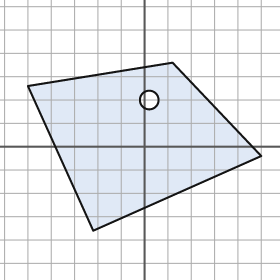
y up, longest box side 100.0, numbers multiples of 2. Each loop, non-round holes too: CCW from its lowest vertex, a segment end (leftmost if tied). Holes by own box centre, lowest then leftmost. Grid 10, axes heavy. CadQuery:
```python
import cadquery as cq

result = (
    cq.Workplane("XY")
    .moveTo(-22.0, -36.0)
    .lineTo(50.0, -4.0)
    .lineTo(12.0, 36.0)
    .lineTo(-50.0, 26.0)
    .close()
    .moveTo(2.0, 20.0)
    .circle(4.0)
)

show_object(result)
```